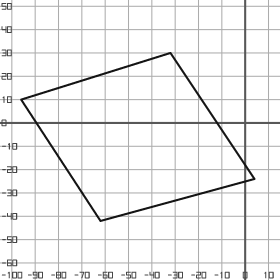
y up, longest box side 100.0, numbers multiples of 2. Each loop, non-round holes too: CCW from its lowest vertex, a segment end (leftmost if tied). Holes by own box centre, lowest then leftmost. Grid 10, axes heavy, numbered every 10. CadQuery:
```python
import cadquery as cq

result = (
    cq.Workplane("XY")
    .moveTo(-62.0, -42.0)
    .lineTo(4.0, -24.0)
    .lineTo(-32.0, 30.0)
    .lineTo(-96.0, 10.0)
    .close()
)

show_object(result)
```